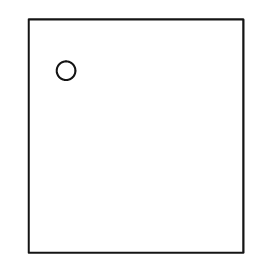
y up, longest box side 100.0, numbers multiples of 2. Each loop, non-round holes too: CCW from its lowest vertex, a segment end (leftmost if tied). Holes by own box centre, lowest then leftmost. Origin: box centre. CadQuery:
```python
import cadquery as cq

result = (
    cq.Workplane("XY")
    .moveTo(-46.0, -50.0)
    .lineTo(46.0, -50.0)
    .lineTo(46.0, 50.0)
    .lineTo(-46.0, 50.0)
    .close()
    .moveTo(-30.0, 28.0)
    .circle(4.0)
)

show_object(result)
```